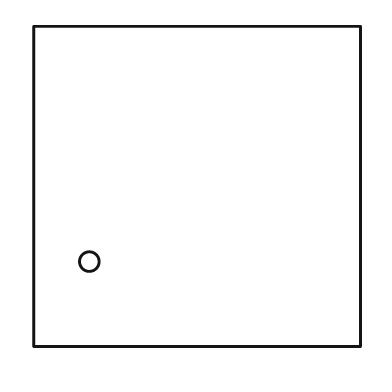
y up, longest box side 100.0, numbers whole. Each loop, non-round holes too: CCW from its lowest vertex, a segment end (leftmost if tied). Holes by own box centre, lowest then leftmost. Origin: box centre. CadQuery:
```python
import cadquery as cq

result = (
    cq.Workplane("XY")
    .moveTo(-50.0, -49.0)
    .lineTo(50.0, -49.0)
    .lineTo(50.0, 49.0)
    .lineTo(-50.0, 49.0)
    .close()
    .moveTo(-33.0, -23.0)
    .circle(3.0)
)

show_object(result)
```